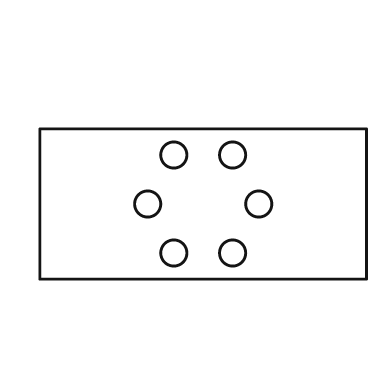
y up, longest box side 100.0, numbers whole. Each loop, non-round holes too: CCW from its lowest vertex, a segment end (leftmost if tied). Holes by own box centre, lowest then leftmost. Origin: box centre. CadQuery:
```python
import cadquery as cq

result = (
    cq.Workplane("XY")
    .moveTo(-50.0, -23.0)
    .lineTo(50.0, -23.0)
    .lineTo(50.0, 23.0)
    .lineTo(-50.0, 23.0)
    .close()
    .moveTo(-9.0, -15.0)
    .circle(4.0)
    .moveTo(9.0, -15.0)
    .circle(4.0)
    .moveTo(-17.0, 0.0)
    .circle(4.0)
    .moveTo(17.0, 0.0)
    .circle(4.0)
    .moveTo(-9.0, 15.0)
    .circle(4.0)
    .moveTo(9.0, 15.0)
    .circle(4.0)
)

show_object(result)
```